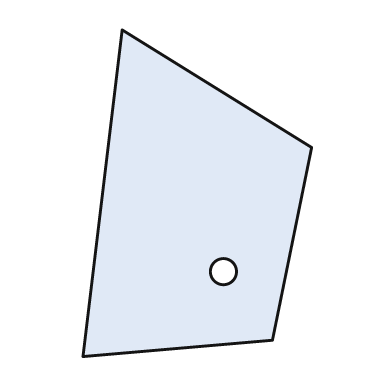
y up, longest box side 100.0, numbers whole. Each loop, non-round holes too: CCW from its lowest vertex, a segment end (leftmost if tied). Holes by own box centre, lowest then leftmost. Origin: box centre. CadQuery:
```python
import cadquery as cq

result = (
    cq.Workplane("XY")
    .moveTo(-35.0, -50.0)
    .lineTo(23.0, -45.0)
    .lineTo(35.0, 14.0)
    .lineTo(-23.0, 50.0)
    .close()
    .moveTo(8.0, -24.0)
    .circle(4.0)
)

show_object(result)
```